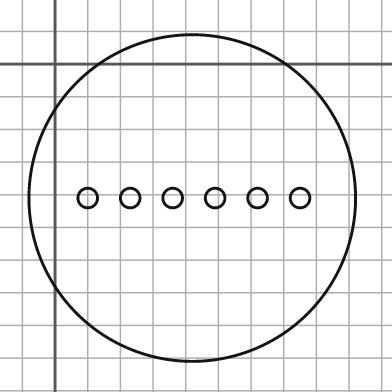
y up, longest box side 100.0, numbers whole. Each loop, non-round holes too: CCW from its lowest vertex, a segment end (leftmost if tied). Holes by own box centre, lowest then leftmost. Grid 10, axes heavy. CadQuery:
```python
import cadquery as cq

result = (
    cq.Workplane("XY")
    .moveTo(42.0, -41.0)
    .circle(50.0)
    .moveTo(10.0, -41.0)
    .circle(3.0)
    .moveTo(23.0, -41.0)
    .circle(3.0)
    .moveTo(36.0, -41.0)
    .circle(3.0)
    .moveTo(49.0, -41.0)
    .circle(3.0)
    .moveTo(62.0, -41.0)
    .circle(3.0)
    .moveTo(75.0, -41.0)
    .circle(3.0)
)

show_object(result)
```